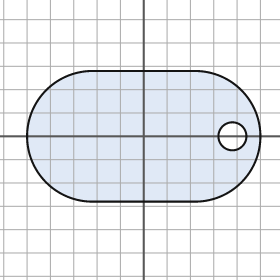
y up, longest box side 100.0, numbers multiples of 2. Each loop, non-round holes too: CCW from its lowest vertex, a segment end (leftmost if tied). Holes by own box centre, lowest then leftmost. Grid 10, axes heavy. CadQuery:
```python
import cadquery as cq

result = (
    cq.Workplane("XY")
    .moveTo(-22.0, -28.0)
    .lineTo(22.0, -28.0)
    .threePointArc((50.0, 0.0), (22.0, 28.0))
    .lineTo(-22.0, 28.0)
    .threePointArc((-50.0, 0.0), (-22.0, -28.0))
    .close()
    .moveTo(38.0, 0.0)
    .circle(6.0)
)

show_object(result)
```